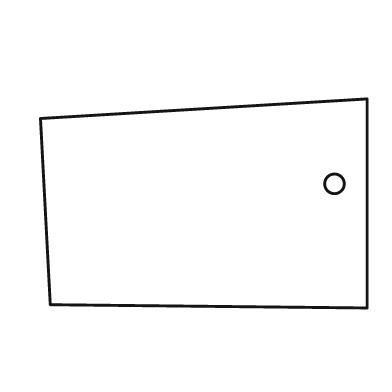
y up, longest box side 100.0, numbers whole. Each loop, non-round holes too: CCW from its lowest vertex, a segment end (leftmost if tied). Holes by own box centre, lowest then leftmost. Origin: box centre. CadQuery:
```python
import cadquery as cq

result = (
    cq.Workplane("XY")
    .moveTo(50.0, -32.0)
    .lineTo(50.0, 32.0)
    .lineTo(-50.0, 26.0)
    .lineTo(-47.0, -31.0)
    .close()
    .moveTo(40.0, 6.0)
    .circle(3.0)
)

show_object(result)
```